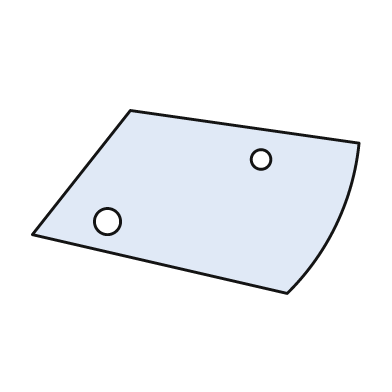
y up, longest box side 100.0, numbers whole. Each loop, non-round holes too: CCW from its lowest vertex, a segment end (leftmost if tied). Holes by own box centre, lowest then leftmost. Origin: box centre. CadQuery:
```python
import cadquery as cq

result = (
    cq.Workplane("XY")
    .moveTo(28.0, -28.0)
    .threePointArc((43.0, -7.0), (50.0, 18.0))
    .lineTo(-20.0, 28.0)
    .lineTo(-50.0, -10.0)
    .close()
    .moveTo(-27.0, -6.0)
    .circle(4.0)
    .moveTo(20.0, 13.0)
    .circle(3.0)
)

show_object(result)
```